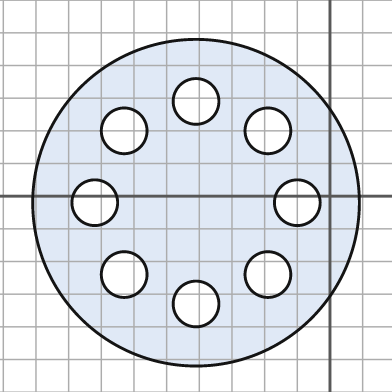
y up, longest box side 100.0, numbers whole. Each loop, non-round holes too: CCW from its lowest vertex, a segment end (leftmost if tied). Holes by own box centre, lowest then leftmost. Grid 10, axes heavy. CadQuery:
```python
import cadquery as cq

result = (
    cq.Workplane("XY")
    .moveTo(-41.0, -2.0)
    .circle(50.0)
    .moveTo(-41.0, -33.0)
    .circle(7.0)
    .moveTo(-63.0, -24.0)
    .circle(7.0)
    .moveTo(-19.0, -24.0)
    .circle(7.0)
    .moveTo(-72.0, -2.0)
    .circle(7.0)
    .moveTo(-10.0, -2.0)
    .circle(7.0)
    .moveTo(-63.0, 20.0)
    .circle(7.0)
    .moveTo(-19.0, 20.0)
    .circle(7.0)
    .moveTo(-41.0, 29.0)
    .circle(7.0)
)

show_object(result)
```